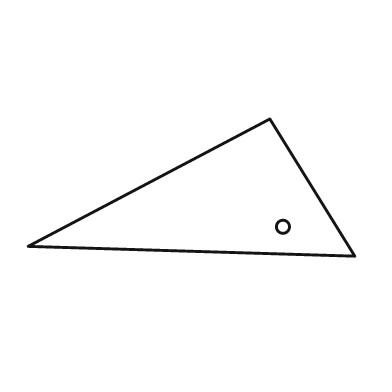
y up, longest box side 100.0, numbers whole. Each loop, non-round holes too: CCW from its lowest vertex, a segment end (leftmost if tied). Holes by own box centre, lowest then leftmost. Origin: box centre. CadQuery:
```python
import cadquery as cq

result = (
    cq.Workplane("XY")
    .moveTo(50.0, -21.0)
    .lineTo(24.0, 21.0)
    .lineTo(-50.0, -18.0)
    .close()
    .moveTo(28.0, -12.0)
    .circle(2.0)
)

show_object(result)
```